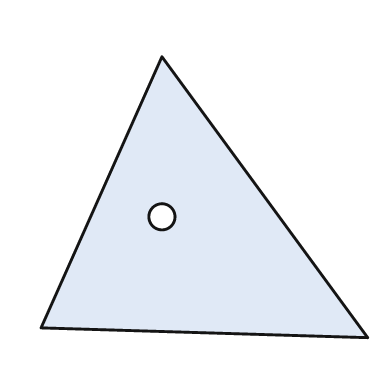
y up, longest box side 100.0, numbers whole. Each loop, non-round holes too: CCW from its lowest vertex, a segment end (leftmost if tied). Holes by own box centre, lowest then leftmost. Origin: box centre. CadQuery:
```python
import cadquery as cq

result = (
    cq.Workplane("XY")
    .moveTo(50.0, -43.0)
    .lineTo(-13.0, 43.0)
    .lineTo(-50.0, -40.0)
    .close()
    .moveTo(-13.0, -6.0)
    .circle(4.0)
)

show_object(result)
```